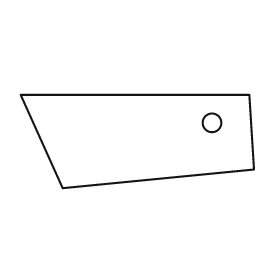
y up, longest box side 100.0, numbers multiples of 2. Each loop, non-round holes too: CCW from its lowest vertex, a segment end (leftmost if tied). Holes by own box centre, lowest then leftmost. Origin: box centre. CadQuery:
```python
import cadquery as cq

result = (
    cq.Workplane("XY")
    .moveTo(-32.0, -20.0)
    .lineTo(50.0, -12.0)
    .lineTo(48.0, 20.0)
    .lineTo(-50.0, 20.0)
    .close()
    .moveTo(32.0, 8.0)
    .circle(4.0)
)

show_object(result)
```